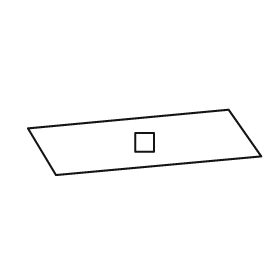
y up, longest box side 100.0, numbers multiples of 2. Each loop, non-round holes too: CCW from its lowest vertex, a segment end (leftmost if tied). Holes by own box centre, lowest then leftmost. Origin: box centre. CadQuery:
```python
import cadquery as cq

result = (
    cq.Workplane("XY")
    .moveTo(-38.0, -14.0)
    .lineTo(50.0, -6.0)
    .lineTo(36.0, 14.0)
    .lineTo(-50.0, 6.0)
    .close()
    .moveTo(-4.0, -4.0)
    .lineTo(4.0, -4.0)
    .lineTo(4.0, 4.0)
    .lineTo(-4.0, 4.0)
    .close()
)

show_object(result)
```